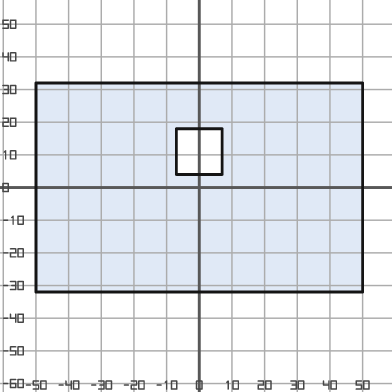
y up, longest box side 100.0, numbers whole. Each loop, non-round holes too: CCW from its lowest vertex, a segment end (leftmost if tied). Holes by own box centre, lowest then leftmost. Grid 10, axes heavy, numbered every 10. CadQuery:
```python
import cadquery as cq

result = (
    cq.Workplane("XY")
    .moveTo(-50.0, -32.0)
    .lineTo(50.0, -32.0)
    .lineTo(50.0, 32.0)
    .lineTo(-50.0, 32.0)
    .close()
    .moveTo(-7.0, 4.0)
    .lineTo(7.0, 4.0)
    .lineTo(7.0, 18.0)
    .lineTo(-7.0, 18.0)
    .close()
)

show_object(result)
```